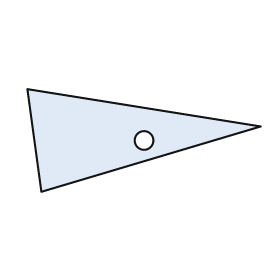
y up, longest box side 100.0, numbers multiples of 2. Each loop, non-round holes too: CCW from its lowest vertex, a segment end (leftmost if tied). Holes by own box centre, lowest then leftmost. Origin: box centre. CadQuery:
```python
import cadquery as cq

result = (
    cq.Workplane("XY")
    .moveTo(-44.0, -22.0)
    .lineTo(50.0, 6.0)
    .lineTo(-50.0, 22.0)
    .close()
    .moveTo(0.0, 0.0)
    .circle(4.0)
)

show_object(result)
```